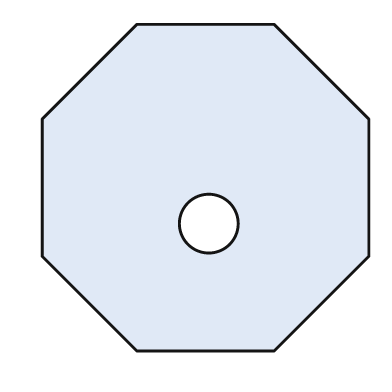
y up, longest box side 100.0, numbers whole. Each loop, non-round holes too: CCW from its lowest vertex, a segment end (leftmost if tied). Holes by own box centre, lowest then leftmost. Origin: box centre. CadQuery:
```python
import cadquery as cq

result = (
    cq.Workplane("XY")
    .moveTo(-21.0, -50.0)
    .lineTo(21.0, -50.0)
    .lineTo(50.0, -21.0)
    .lineTo(50.0, 21.0)
    .lineTo(21.0, 50.0)
    .lineTo(-21.0, 50.0)
    .lineTo(-50.0, 21.0)
    .lineTo(-50.0, -21.0)
    .close()
    .moveTo(1.0, -11.0)
    .circle(9.0)
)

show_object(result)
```